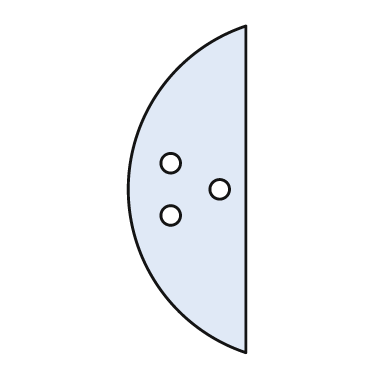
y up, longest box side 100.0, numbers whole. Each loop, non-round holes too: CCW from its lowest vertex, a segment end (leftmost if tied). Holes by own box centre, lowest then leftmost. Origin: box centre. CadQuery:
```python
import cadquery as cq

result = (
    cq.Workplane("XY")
    .moveTo(18.0, -50.0)
    .lineTo(18.0, 50.0)
    .threePointArc((-18.0, 0.0), (18.0, -50.0))
    .close()
    .moveTo(-5.0, -8.0)
    .circle(3.0)
    .moveTo(10.0, 0.0)
    .circle(3.0)
    .moveTo(-5.0, 8.0)
    .circle(3.0)
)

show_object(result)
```